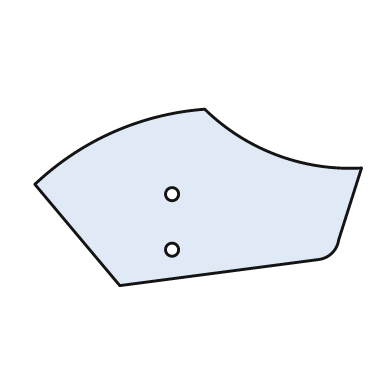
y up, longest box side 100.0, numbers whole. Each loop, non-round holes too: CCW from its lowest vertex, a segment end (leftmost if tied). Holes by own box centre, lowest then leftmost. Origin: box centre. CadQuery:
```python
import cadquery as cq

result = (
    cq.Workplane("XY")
    .moveTo(-24.0, -27.0)
    .lineTo(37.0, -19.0)
    .threePointArc((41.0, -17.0), (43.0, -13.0))
    .lineTo(50.0, 9.0)
    .threePointArc((24.0, 13.0), (2.0, 27.0))
    .threePointArc((-26.0, 20.0), (-50.0, 4.0))
    .close()
    .moveTo(-8.0, -16.0)
    .circle(2.0)
    .moveTo(-8.0, 1.0)
    .circle(2.0)
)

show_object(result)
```